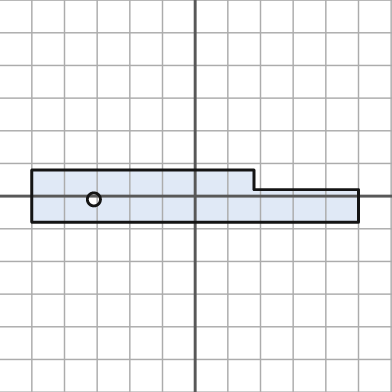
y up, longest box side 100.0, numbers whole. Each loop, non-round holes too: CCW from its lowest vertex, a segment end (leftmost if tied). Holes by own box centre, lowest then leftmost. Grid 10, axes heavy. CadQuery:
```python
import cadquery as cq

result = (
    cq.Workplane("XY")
    .moveTo(-50.0, -8.0)
    .lineTo(50.0, -8.0)
    .lineTo(50.0, 2.0)
    .lineTo(18.0, 2.0)
    .lineTo(18.0, 8.0)
    .lineTo(-50.0, 8.0)
    .close()
    .moveTo(-31.0, -1.0)
    .circle(2.0)
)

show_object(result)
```